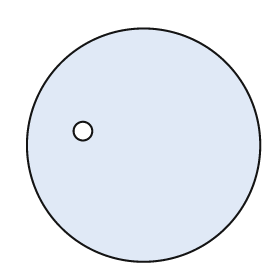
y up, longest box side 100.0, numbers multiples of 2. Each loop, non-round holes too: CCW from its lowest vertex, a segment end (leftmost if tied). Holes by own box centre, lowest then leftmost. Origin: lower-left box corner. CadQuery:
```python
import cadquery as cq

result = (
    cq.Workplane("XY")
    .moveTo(50.0, 50.0)
    .circle(50.0)
    .moveTo(24.0, 56.0)
    .circle(4.0)
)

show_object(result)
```